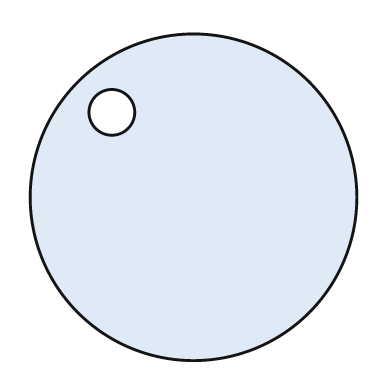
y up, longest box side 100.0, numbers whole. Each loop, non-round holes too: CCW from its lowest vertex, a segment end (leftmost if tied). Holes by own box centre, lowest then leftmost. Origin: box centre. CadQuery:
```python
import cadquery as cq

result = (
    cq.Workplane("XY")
    .moveTo(0.0, 0.0)
    .circle(50.0)
    .moveTo(-25.0, 26.0)
    .circle(7.0)
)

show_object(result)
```